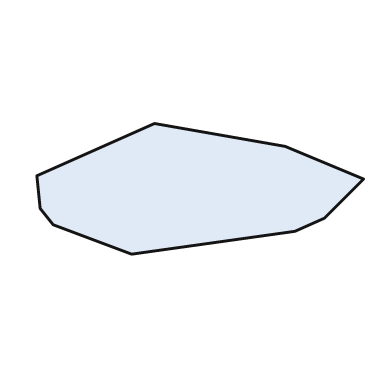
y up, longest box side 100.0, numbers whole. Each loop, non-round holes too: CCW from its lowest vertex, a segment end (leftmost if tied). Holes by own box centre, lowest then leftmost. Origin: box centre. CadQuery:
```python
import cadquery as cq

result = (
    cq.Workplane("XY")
    .moveTo(-21.0, -20.0)
    .lineTo(29.0, -13.0)
    .lineTo(38.0, -9.0)
    .lineTo(50.0, 3.0)
    .lineTo(26.0, 13.0)
    .lineTo(-14.0, 20.0)
    .lineTo(-50.0, 4.0)
    .lineTo(-49.0, -6.0)
    .lineTo(-45.0, -11.0)
    .close()
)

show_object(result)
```